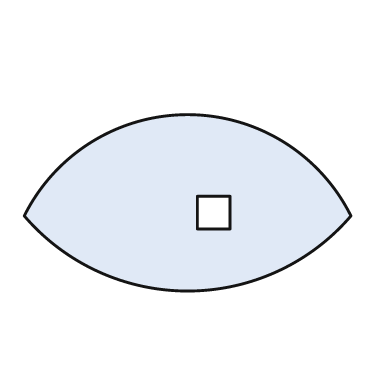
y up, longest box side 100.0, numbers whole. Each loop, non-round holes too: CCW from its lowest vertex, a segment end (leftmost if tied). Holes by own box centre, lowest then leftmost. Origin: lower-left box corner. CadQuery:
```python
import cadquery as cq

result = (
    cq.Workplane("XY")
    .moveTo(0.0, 23.0)
    .threePointArc((50.0, 0.0), (100.0, 23.0))
    .threePointArc((50.0, 54.0), (0.0, 23.0))
    .close()
    .moveTo(53.0, 19.0)
    .lineTo(63.0, 19.0)
    .lineTo(63.0, 29.0)
    .lineTo(53.0, 29.0)
    .close()
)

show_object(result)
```